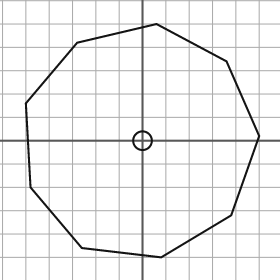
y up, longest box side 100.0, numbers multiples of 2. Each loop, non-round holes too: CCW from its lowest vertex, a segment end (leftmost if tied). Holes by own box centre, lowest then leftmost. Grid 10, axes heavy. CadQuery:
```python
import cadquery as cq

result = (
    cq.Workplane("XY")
    .moveTo(8.0, -50.0)
    .lineTo(38.0, -32.0)
    .lineTo(50.0, 2.0)
    .lineTo(36.0, 34.0)
    .lineTo(6.0, 50.0)
    .lineTo(-28.0, 42.0)
    .lineTo(-50.0, 16.0)
    .lineTo(-48.0, -20.0)
    .lineTo(-26.0, -46.0)
    .close()
    .moveTo(0.0, 0.0)
    .circle(4.0)
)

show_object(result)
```